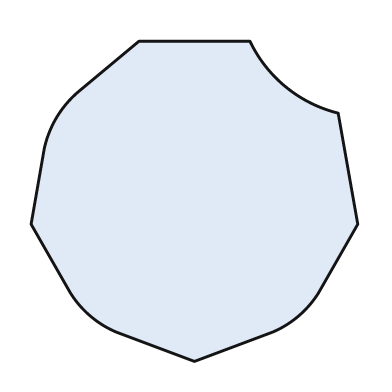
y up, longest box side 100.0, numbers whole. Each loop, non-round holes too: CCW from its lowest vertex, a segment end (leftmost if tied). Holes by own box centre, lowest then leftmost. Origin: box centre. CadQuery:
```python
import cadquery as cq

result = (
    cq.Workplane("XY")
    .moveTo(0.0, -49.0)
    .lineTo(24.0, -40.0)
    .threePointArc((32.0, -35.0), (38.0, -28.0))
    .lineTo(50.0, -7.0)
    .lineTo(44.0, 27.0)
    .threePointArc((28.0, 35.0), (17.0, 49.0))
    .lineTo(-17.0, 49.0)
    .lineTo(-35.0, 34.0)
    .threePointArc((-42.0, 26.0), (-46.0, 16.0))
    .lineTo(-50.0, -7.0)
    .lineTo(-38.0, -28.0)
    .threePointArc((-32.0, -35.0), (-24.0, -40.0))
    .close()
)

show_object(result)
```